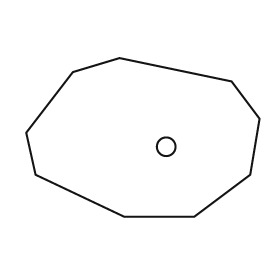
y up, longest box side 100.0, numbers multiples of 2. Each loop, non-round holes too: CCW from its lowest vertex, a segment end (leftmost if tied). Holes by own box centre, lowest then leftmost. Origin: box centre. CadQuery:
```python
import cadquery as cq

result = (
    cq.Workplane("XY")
    .moveTo(-8.0, -34.0)
    .lineTo(22.0, -34.0)
    .lineTo(46.0, -16.0)
    .lineTo(50.0, 8.0)
    .lineTo(38.0, 24.0)
    .lineTo(-10.0, 34.0)
    .lineTo(-30.0, 28.0)
    .lineTo(-50.0, 2.0)
    .lineTo(-46.0, -16.0)
    .close()
    .moveTo(10.0, -4.0)
    .circle(4.0)
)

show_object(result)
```